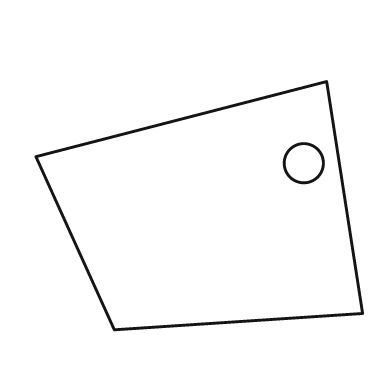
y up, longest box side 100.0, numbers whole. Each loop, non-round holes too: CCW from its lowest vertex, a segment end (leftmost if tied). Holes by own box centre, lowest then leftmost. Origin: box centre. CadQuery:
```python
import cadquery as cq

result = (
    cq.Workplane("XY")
    .moveTo(-26.0, -38.0)
    .lineTo(50.0, -33.0)
    .lineTo(39.0, 38.0)
    .lineTo(-50.0, 15.0)
    .close()
    .moveTo(32.0, 13.0)
    .circle(6.0)
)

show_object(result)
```